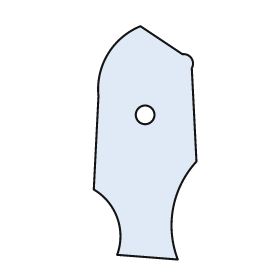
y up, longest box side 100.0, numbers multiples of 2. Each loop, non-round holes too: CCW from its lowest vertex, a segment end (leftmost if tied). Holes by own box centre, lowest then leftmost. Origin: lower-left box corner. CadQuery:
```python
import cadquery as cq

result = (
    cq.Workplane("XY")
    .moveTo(36.0, 0.0)
    .threePointArc((34.0, 22.0), (44.0, 42.0))
    .lineTo(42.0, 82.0)
    .threePointArc((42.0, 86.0), (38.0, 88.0))
    .lineTo(20.0, 100.0)
    .threePointArc((6.0, 88.0), (2.0, 70.0))
    .lineTo(0.0, 30.0)
    .threePointArc((10.0, 18.0), (10.0, 2.0))
    .close()
    .moveTo(22.0, 62.0)
    .circle(4.0)
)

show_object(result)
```